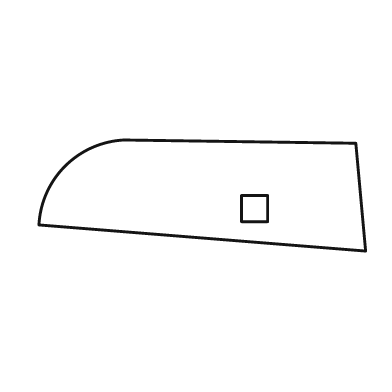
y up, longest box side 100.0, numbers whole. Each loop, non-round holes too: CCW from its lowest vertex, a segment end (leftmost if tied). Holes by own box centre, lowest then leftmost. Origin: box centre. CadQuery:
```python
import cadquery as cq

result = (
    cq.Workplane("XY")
    .moveTo(50.0, -17.0)
    .lineTo(47.0, 16.0)
    .lineTo(-24.0, 17.0)
    .threePointArc((-42.0, 9.0), (-50.0, -9.0))
    .close()
    .moveTo(12.0, -8.0)
    .lineTo(20.0, -8.0)
    .lineTo(20.0, 0.0)
    .lineTo(12.0, 0.0)
    .close()
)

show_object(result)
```